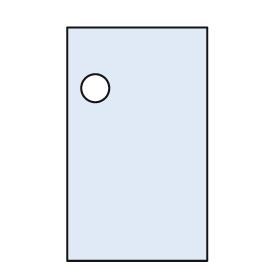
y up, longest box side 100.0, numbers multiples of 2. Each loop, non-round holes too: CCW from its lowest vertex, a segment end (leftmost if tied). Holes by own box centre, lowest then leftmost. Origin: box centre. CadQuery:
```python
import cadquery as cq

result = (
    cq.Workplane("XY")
    .moveTo(-30.0, -50.0)
    .lineTo(30.0, -50.0)
    .lineTo(30.0, 50.0)
    .lineTo(-30.0, 50.0)
    .close()
    .moveTo(-18.0, 24.0)
    .circle(6.0)
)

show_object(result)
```